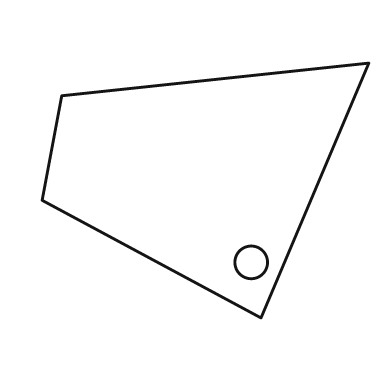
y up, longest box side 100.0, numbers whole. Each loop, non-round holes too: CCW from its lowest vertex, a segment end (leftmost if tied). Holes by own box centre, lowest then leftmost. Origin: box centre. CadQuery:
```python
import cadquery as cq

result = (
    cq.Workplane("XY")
    .moveTo(17.0, -39.0)
    .lineTo(50.0, 39.0)
    .lineTo(-44.0, 29.0)
    .lineTo(-50.0, -3.0)
    .close()
    .moveTo(14.0, -22.0)
    .circle(5.0)
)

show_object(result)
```